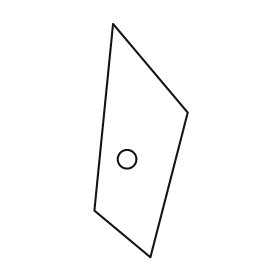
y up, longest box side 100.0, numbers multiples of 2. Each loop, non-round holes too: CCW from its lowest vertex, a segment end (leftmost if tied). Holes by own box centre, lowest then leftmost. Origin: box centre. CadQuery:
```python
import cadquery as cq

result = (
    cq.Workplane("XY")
    .moveTo(4.0, -50.0)
    .lineTo(20.0, 12.0)
    .lineTo(-12.0, 50.0)
    .lineTo(-20.0, -30.0)
    .close()
    .moveTo(-6.0, -8.0)
    .circle(4.0)
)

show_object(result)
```